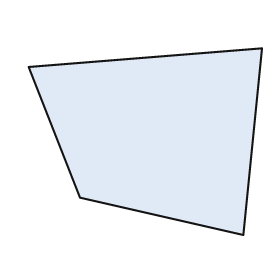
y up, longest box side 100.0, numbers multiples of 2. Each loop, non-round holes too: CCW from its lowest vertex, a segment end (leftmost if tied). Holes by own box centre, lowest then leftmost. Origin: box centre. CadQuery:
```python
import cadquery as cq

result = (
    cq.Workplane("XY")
    .moveTo(42.0, -40.0)
    .lineTo(50.0, 40.0)
    .lineTo(-50.0, 32.0)
    .lineTo(-28.0, -24.0)
    .close()
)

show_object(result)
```